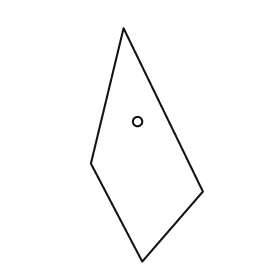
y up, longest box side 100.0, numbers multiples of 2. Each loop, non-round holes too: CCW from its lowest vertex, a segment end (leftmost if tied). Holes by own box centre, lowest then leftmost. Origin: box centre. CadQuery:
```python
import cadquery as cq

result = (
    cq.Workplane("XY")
    .moveTo(-2.0, -50.0)
    .lineTo(24.0, -20.0)
    .lineTo(-10.0, 50.0)
    .lineTo(-24.0, -8.0)
    .close()
    .moveTo(-4.0, 10.0)
    .circle(2.0)
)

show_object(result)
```